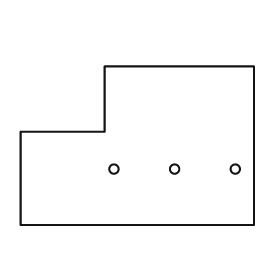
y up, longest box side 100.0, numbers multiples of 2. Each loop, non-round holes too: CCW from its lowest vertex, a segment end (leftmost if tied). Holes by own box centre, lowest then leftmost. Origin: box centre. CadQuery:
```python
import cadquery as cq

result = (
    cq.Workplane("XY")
    .moveTo(-50.0, -34.0)
    .lineTo(50.0, -34.0)
    .lineTo(50.0, 34.0)
    .lineTo(-14.0, 34.0)
    .lineTo(-14.0, 6.0)
    .lineTo(-50.0, 6.0)
    .close()
    .moveTo(-10.0, -10.0)
    .circle(2.0)
    .moveTo(16.0, -10.0)
    .circle(2.0)
    .moveTo(42.0, -10.0)
    .circle(2.0)
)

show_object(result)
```